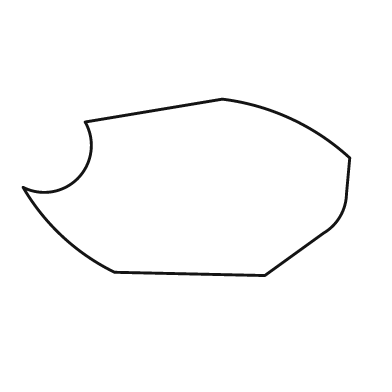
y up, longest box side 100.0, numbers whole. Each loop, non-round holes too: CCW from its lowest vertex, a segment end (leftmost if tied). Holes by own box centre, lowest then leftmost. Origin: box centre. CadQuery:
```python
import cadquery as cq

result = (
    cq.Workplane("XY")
    .moveTo(24.0, -27.0)
    .lineTo(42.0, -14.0)
    .threePointArc((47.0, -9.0), (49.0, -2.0))
    .lineTo(50.0, 9.0)
    .threePointArc((32.0, 21.0), (11.0, 27.0))
    .lineTo(-31.0, 20.0)
    .threePointArc((-33.0, 3.0), (-50.0, 0.0))
    .threePointArc((-38.0, -15.0), (-22.0, -26.0))
    .close()
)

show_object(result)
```